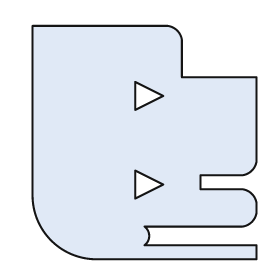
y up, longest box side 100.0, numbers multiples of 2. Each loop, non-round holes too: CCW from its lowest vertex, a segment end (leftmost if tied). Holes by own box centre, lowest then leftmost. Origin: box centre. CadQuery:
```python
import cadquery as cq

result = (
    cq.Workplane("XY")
    .moveTo(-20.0, -50.0)
    .lineTo(48.0, -50.0)
    .lineTo(48.0, -44.0)
    .lineTo(0.0, -44.0)
    .threePointArc((2.0, -40.0), (0.0, -36.0))
    .lineTo(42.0, -36.0)
    .threePointArc((46.0, -34.0), (48.0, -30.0))
    .lineTo(48.0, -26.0)
    .threePointArc((46.0, -22.0), (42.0, -20.0))
    .lineTo(24.0, -20.0)
    .lineTo(24.0, -14.0)
    .lineTo(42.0, -14.0)
    .threePointArc((46.0, -12.0), (48.0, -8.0))
    .lineTo(48.0, 28.0)
    .lineTo(16.0, 28.0)
    .lineTo(16.0, 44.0)
    .threePointArc((14.0, 48.0), (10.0, 50.0))
    .lineTo(-48.0, 50.0)
    .lineTo(-48.0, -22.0)
    .threePointArc((-40.0, -42.0), (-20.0, -50.0))
    .close()
    .moveTo(-4.0, -24.0)
    .lineTo(8.0, -18.0)
    .lineTo(-4.0, -12.0)
    .close()
    .moveTo(-4.0, 14.0)
    .lineTo(8.0, 20.0)
    .lineTo(-4.0, 26.0)
    .close()
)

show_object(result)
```